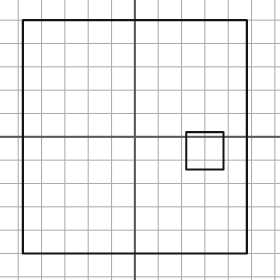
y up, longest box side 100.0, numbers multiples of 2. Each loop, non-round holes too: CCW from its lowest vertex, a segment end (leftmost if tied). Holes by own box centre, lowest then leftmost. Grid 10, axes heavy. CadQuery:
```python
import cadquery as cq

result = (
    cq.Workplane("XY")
    .moveTo(-48.0, -50.0)
    .lineTo(48.0, -50.0)
    .lineTo(48.0, 50.0)
    .lineTo(-48.0, 50.0)
    .close()
    .moveTo(22.0, -14.0)
    .lineTo(38.0, -14.0)
    .lineTo(38.0, 2.0)
    .lineTo(22.0, 2.0)
    .close()
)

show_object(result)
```